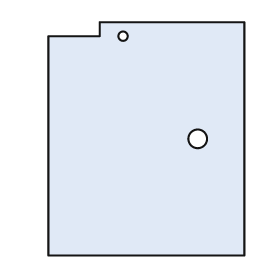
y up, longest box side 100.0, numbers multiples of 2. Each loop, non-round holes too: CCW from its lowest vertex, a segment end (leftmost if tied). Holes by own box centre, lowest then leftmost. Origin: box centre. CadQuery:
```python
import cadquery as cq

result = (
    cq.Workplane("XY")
    .moveTo(-42.0, -50.0)
    .lineTo(42.0, -50.0)
    .lineTo(42.0, 50.0)
    .lineTo(-20.0, 50.0)
    .lineTo(-20.0, 44.0)
    .lineTo(-42.0, 44.0)
    .close()
    .moveTo(22.0, 0.0)
    .circle(4.0)
    .moveTo(-10.0, 44.0)
    .circle(2.0)
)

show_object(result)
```